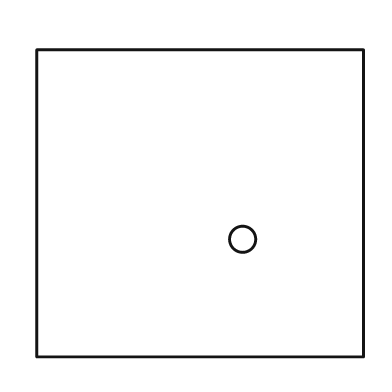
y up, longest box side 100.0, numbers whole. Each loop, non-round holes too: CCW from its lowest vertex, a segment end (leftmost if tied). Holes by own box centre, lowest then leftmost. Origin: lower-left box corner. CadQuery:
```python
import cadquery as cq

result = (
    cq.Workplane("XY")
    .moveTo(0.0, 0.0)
    .lineTo(100.0, 0.0)
    .lineTo(100.0, 94.0)
    .lineTo(0.0, 94.0)
    .close()
    .moveTo(63.0, 36.0)
    .circle(4.0)
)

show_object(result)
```